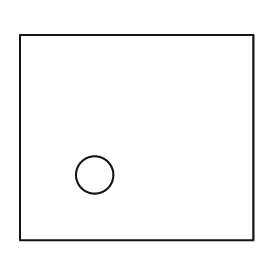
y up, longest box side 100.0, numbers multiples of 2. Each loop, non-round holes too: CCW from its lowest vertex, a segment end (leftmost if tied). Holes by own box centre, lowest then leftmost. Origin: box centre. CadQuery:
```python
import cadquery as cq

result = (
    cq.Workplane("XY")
    .moveTo(-50.0, -44.0)
    .lineTo(50.0, -44.0)
    .lineTo(50.0, 44.0)
    .lineTo(-50.0, 44.0)
    .close()
    .moveTo(-18.0, -16.0)
    .circle(8.0)
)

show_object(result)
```